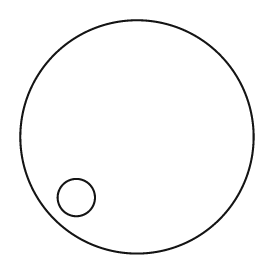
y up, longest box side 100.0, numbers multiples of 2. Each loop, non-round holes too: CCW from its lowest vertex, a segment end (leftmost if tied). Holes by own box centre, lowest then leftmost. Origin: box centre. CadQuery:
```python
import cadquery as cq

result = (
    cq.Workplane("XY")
    .moveTo(0.0, 0.0)
    .circle(50.0)
    .moveTo(-26.0, -26.0)
    .circle(8.0)
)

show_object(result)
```